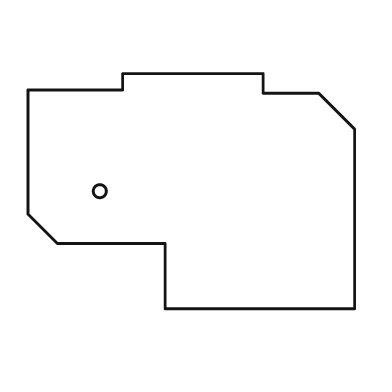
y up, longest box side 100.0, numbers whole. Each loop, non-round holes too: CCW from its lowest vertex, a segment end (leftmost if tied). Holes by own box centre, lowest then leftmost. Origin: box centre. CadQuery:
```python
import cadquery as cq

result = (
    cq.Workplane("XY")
    .moveTo(-8.0, -36.0)
    .lineTo(50.0, -36.0)
    .lineTo(50.0, 19.0)
    .lineTo(39.0, 30.0)
    .lineTo(22.0, 30.0)
    .lineTo(22.0, 36.0)
    .lineTo(-21.0, 36.0)
    .lineTo(-21.0, 31.0)
    .lineTo(-50.0, 31.0)
    .lineTo(-50.0, -7.0)
    .lineTo(-41.0, -16.0)
    .lineTo(-8.0, -16.0)
    .close()
    .moveTo(-28.0, 0.0)
    .circle(2.0)
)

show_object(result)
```